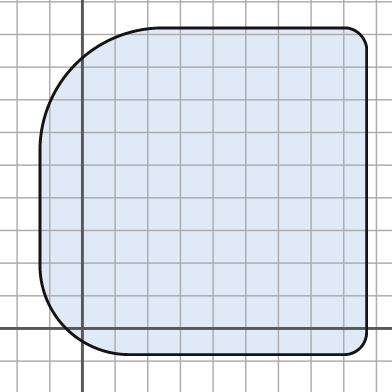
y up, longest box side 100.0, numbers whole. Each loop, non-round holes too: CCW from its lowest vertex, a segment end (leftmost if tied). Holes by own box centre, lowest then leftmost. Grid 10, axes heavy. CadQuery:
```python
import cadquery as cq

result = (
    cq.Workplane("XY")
    .moveTo(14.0, -8.0)
    .lineTo(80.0, -8.0)
    .threePointArc((85.0, -6.0), (87.0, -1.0))
    .lineTo(87.0, 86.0)
    .threePointArc((85.0, 90.0), (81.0, 92.0))
    .lineTo(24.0, 92.0)
    .threePointArc((-2.0, 81.0), (-13.0, 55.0))
    .lineTo(-13.0, 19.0)
    .threePointArc((-5.0, 0.0), (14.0, -8.0))
    .close()
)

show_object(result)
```